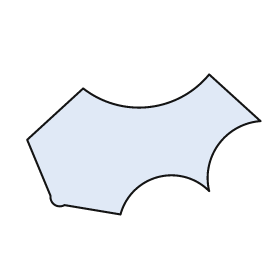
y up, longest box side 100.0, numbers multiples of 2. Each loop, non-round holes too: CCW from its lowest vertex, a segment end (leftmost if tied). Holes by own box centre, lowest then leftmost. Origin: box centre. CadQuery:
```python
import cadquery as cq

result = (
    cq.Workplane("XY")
    .moveTo(-10.0, -30.0)
    .threePointArc((6.0, -14.0), (28.0, -20.0))
    .threePointArc((32.0, 0.0), (50.0, 10.0))
    .lineTo(28.0, 30.0)
    .threePointArc((2.0, 16.0), (-26.0, 24.0))
    .lineTo(-50.0, 2.0)
    .lineTo(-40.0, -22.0)
    .threePointArc((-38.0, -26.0), (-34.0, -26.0))
    .close()
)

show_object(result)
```